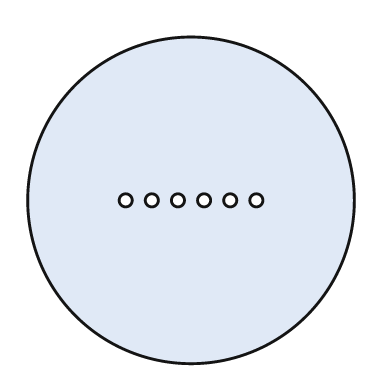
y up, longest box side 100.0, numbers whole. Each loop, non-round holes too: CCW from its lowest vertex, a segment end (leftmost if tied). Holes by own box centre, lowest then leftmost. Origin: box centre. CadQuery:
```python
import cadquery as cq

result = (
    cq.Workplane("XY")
    .moveTo(0.0, 0.0)
    .circle(50.0)
    .moveTo(-20.0, 0.0)
    .circle(2.0)
    .moveTo(-12.0, 0.0)
    .circle(2.0)
    .moveTo(-4.0, 0.0)
    .circle(2.0)
    .moveTo(4.0, 0.0)
    .circle(2.0)
    .moveTo(12.0, 0.0)
    .circle(2.0)
    .moveTo(20.0, 0.0)
    .circle(2.0)
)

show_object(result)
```